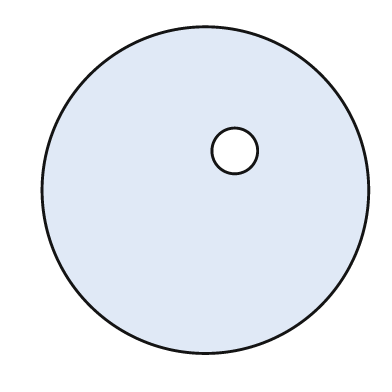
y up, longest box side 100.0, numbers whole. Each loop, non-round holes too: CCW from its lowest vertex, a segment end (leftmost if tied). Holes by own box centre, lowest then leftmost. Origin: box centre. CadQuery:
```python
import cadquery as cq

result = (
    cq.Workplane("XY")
    .moveTo(0.0, 0.0)
    .circle(50.0)
    .moveTo(9.0, 12.0)
    .circle(7.0)
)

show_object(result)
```